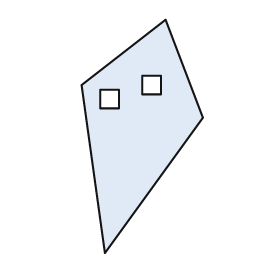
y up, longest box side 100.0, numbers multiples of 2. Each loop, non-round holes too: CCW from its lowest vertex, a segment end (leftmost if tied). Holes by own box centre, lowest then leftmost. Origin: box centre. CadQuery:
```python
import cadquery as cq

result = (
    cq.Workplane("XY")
    .moveTo(-16.0, -50.0)
    .lineTo(26.0, 8.0)
    .lineTo(10.0, 50.0)
    .lineTo(-26.0, 22.0)
    .close()
    .moveTo(-18.0, 12.0)
    .lineTo(-10.0, 12.0)
    .lineTo(-10.0, 20.0)
    .lineTo(-18.0, 20.0)
    .close()
    .moveTo(0.0, 18.0)
    .lineTo(8.0, 18.0)
    .lineTo(8.0, 26.0)
    .lineTo(0.0, 26.0)
    .close()
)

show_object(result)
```